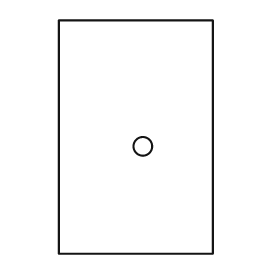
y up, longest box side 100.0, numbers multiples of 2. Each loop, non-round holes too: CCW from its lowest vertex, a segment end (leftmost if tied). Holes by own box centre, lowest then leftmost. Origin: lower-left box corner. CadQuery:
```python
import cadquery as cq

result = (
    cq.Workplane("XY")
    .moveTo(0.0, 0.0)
    .lineTo(66.0, 0.0)
    .lineTo(66.0, 100.0)
    .lineTo(0.0, 100.0)
    .close()
    .moveTo(36.0, 46.0)
    .circle(4.0)
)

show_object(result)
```